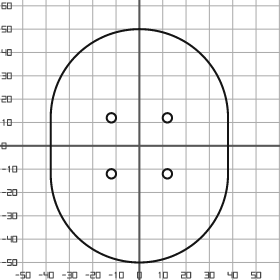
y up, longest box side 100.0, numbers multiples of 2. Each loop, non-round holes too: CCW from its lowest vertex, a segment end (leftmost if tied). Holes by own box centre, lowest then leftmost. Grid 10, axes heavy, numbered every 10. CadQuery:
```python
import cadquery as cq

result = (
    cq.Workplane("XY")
    .moveTo(-38.0, -12.0)
    .threePointArc((0.0, -50.0), (38.0, -12.0))
    .lineTo(38.0, 12.0)
    .threePointArc((0.0, 50.0), (-38.0, 12.0))
    .close()
    .moveTo(-12.0, -12.0)
    .circle(2.0)
    .moveTo(12.0, -12.0)
    .circle(2.0)
    .moveTo(-12.0, 12.0)
    .circle(2.0)
    .moveTo(12.0, 12.0)
    .circle(2.0)
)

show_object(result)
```